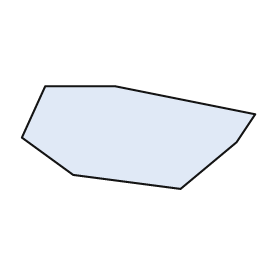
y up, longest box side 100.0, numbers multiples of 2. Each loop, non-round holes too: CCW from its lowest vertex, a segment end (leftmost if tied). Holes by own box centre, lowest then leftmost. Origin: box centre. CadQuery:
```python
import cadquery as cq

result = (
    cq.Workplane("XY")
    .moveTo(18.0, -22.0)
    .lineTo(42.0, -2.0)
    .lineTo(50.0, 10.0)
    .lineTo(-10.0, 22.0)
    .lineTo(-40.0, 22.0)
    .lineTo(-50.0, 0.0)
    .lineTo(-28.0, -16.0)
    .close()
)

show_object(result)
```